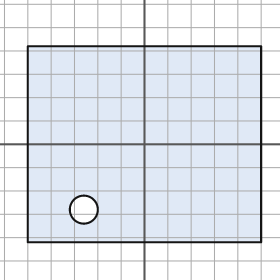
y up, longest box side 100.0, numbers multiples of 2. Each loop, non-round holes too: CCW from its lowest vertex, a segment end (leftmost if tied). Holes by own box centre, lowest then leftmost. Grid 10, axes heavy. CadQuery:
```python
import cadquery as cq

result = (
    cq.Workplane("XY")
    .moveTo(-50.0, -42.0)
    .lineTo(50.0, -42.0)
    .lineTo(50.0, 42.0)
    .lineTo(-50.0, 42.0)
    .close()
    .moveTo(-26.0, -28.0)
    .circle(6.0)
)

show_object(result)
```